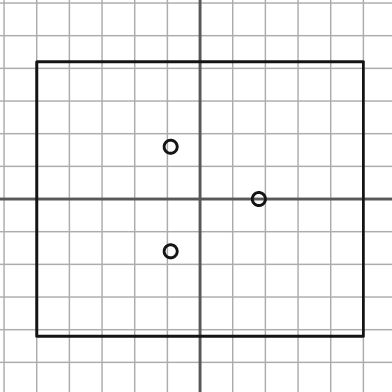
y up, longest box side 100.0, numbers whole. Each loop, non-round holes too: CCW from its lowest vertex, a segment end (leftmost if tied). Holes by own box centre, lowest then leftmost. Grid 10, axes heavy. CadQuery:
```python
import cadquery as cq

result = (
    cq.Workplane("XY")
    .moveTo(-50.0, -42.0)
    .lineTo(50.0, -42.0)
    .lineTo(50.0, 42.0)
    .lineTo(-50.0, 42.0)
    .close()
    .moveTo(-9.0, -16.0)
    .circle(2.0)
    .moveTo(18.0, 0.0)
    .circle(2.0)
    .moveTo(-9.0, 16.0)
    .circle(2.0)
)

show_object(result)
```